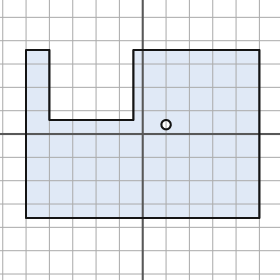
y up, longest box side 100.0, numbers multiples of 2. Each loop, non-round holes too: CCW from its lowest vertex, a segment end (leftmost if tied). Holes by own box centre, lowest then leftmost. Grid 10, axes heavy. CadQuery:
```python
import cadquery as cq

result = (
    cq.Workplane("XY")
    .moveTo(-50.0, -36.0)
    .lineTo(50.0, -36.0)
    .lineTo(50.0, 36.0)
    .lineTo(-4.0, 36.0)
    .lineTo(-4.0, 6.0)
    .lineTo(-40.0, 6.0)
    .lineTo(-40.0, 36.0)
    .lineTo(-50.0, 36.0)
    .close()
    .moveTo(10.0, 4.0)
    .circle(2.0)
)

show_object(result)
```